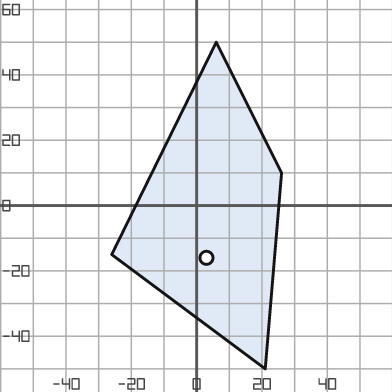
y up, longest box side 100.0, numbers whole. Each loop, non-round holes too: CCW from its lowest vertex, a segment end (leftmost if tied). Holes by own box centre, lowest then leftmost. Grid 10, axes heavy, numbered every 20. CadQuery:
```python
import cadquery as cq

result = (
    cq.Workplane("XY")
    .moveTo(21.0, -50.0)
    .lineTo(26.0, 10.0)
    .lineTo(6.0, 50.0)
    .lineTo(-26.0, -15.0)
    .close()
    .moveTo(3.0, -16.0)
    .circle(2.0)
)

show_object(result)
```